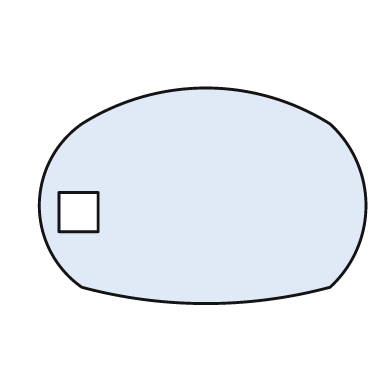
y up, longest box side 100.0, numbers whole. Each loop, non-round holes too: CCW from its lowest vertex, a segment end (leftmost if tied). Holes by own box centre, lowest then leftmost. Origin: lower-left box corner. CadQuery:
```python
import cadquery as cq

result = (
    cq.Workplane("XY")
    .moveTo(13.0, 5.0)
    .threePointArc((51.0, 0.0), (89.0, 5.0))
    .threePointArc((100.0, 30.0), (89.0, 55.0))
    .threePointArc((51.0, 66.0), (13.0, 55.0))
    .threePointArc((0.0, 30.0), (13.0, 5.0))
    .close()
    .moveTo(6.0, 22.0)
    .lineTo(18.0, 22.0)
    .lineTo(18.0, 34.0)
    .lineTo(6.0, 34.0)
    .close()
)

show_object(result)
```